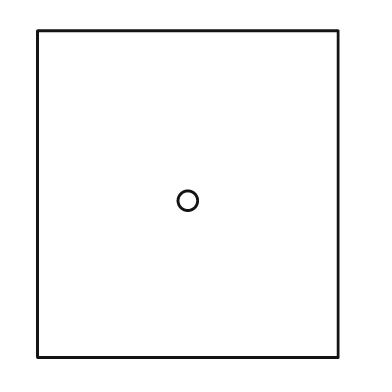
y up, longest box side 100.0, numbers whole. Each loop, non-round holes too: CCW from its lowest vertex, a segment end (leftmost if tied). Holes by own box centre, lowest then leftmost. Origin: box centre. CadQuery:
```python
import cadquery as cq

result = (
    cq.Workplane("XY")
    .moveTo(-46.0, -50.0)
    .lineTo(46.0, -50.0)
    .lineTo(46.0, 50.0)
    .lineTo(-46.0, 50.0)
    .close()
    .moveTo(0.0, -2.0)
    .circle(3.0)
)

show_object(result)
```